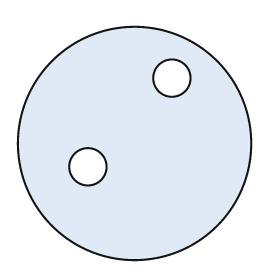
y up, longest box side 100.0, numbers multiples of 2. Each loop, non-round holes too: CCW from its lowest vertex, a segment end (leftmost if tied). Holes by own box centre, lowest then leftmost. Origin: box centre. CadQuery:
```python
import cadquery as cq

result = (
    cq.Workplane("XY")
    .moveTo(0.0, 0.0)
    .circle(50.0)
    .moveTo(-20.0, -10.0)
    .circle(8.0)
    .moveTo(16.0, 28.0)
    .circle(8.0)
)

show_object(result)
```